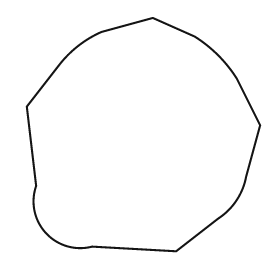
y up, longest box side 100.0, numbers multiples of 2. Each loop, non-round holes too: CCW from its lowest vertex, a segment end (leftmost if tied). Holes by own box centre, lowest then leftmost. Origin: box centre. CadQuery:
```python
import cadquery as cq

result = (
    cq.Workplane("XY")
    .moveTo(14.0, -50.0)
    .lineTo(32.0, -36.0)
    .threePointArc((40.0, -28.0), (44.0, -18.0))
    .lineTo(50.0, 4.0)
    .lineTo(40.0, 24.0)
    .threePointArc((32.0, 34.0), (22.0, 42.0))
    .lineTo(4.0, 50.0)
    .lineTo(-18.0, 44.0)
    .threePointArc((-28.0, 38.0), (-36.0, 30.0))
    .lineTo(-50.0, 12.0)
    .lineTo(-46.0, -22.0)
    .threePointArc((-42.0, -42.0), (-22.0, -48.0))
    .close()
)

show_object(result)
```